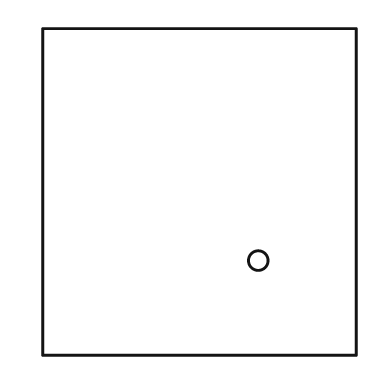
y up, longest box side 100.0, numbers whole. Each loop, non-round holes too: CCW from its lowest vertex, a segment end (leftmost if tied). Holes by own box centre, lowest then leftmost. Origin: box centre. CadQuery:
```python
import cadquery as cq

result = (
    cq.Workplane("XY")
    .moveTo(-48.0, -50.0)
    .lineTo(48.0, -50.0)
    .lineTo(48.0, 50.0)
    .lineTo(-48.0, 50.0)
    .close()
    .moveTo(18.0, -21.0)
    .circle(3.0)
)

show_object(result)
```